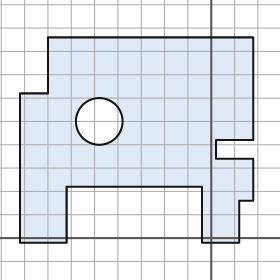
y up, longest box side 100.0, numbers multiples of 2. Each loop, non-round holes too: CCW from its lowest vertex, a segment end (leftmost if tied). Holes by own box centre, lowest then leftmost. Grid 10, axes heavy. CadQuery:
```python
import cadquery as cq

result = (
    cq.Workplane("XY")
    .moveTo(-82.0, -2.0)
    .lineTo(-62.0, -2.0)
    .lineTo(-62.0, 22.0)
    .lineTo(-4.0, 22.0)
    .lineTo(-4.0, -2.0)
    .lineTo(12.0, -2.0)
    .lineTo(12.0, 16.0)
    .lineTo(18.0, 16.0)
    .lineTo(18.0, 34.0)
    .lineTo(2.0, 34.0)
    .lineTo(2.0, 42.0)
    .lineTo(18.0, 42.0)
    .lineTo(18.0, 86.0)
    .lineTo(-70.0, 86.0)
    .lineTo(-70.0, 62.0)
    .lineTo(-82.0, 62.0)
    .close()
    .moveTo(-48.0, 50.0)
    .circle(10.0)
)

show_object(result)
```